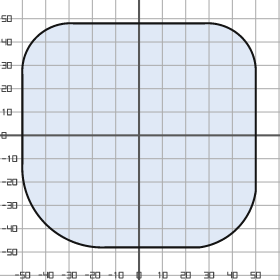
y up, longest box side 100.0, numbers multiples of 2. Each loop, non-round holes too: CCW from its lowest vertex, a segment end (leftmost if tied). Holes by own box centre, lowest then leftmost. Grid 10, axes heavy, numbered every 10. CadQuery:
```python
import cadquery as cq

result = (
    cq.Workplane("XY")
    .moveTo(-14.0, -48.0)
    .lineTo(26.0, -48.0)
    .threePointArc((42.0, -40.0), (50.0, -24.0))
    .lineTo(50.0, 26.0)
    .threePointArc((44.0, 42.0), (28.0, 48.0))
    .lineTo(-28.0, 48.0)
    .threePointArc((-44.0, 42.0), (-50.0, 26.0))
    .lineTo(-50.0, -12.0)
    .threePointArc((-40.0, -38.0), (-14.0, -48.0))
    .close()
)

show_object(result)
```